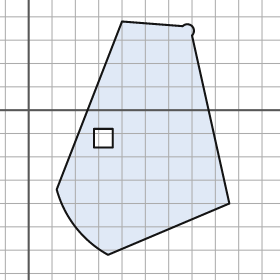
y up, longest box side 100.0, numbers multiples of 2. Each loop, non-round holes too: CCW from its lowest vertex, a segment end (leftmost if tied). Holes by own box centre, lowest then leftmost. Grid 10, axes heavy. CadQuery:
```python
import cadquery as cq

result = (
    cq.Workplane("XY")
    .moveTo(34.0, -62.0)
    .lineTo(86.0, -40.0)
    .lineTo(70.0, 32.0)
    .threePointArc((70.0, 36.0), (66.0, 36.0))
    .lineTo(40.0, 38.0)
    .lineTo(12.0, -34.0)
    .threePointArc((20.0, -50.0), (34.0, -62.0))
    .close()
    .moveTo(28.0, -16.0)
    .lineTo(36.0, -16.0)
    .lineTo(36.0, -8.0)
    .lineTo(28.0, -8.0)
    .close()
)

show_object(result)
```